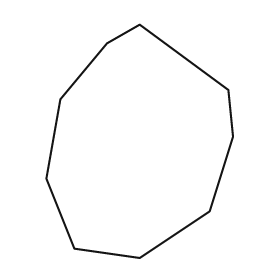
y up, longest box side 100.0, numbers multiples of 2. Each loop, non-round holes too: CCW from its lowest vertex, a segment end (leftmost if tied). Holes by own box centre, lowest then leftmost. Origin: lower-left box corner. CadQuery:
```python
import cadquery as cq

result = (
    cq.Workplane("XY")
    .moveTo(40.0, 0.0)
    .lineTo(70.0, 20.0)
    .lineTo(80.0, 52.0)
    .lineTo(78.0, 72.0)
    .lineTo(40.0, 100.0)
    .lineTo(26.0, 92.0)
    .lineTo(6.0, 68.0)
    .lineTo(0.0, 34.0)
    .lineTo(12.0, 4.0)
    .close()
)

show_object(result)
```